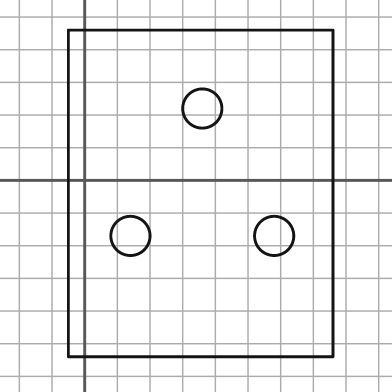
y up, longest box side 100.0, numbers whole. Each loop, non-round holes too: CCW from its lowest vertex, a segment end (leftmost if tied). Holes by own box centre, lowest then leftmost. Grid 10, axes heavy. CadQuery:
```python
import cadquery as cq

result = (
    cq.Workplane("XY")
    .moveTo(-5.0, -54.0)
    .lineTo(76.0, -54.0)
    .lineTo(76.0, 46.0)
    .lineTo(-5.0, 46.0)
    .close()
    .moveTo(14.0, -17.0)
    .circle(6.0)
    .moveTo(58.0, -17.0)
    .circle(6.0)
    .moveTo(36.0, 22.0)
    .circle(6.0)
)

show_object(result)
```